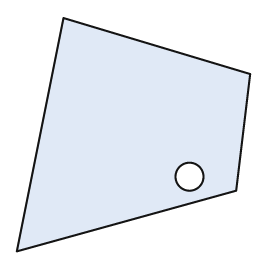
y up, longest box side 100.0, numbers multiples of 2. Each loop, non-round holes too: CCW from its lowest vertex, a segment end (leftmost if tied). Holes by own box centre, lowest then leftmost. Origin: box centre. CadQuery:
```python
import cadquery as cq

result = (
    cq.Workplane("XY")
    .moveTo(-50.0, -50.0)
    .lineTo(44.0, -24.0)
    .lineTo(50.0, 26.0)
    .lineTo(-30.0, 50.0)
    .close()
    .moveTo(24.0, -18.0)
    .circle(6.0)
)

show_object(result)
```